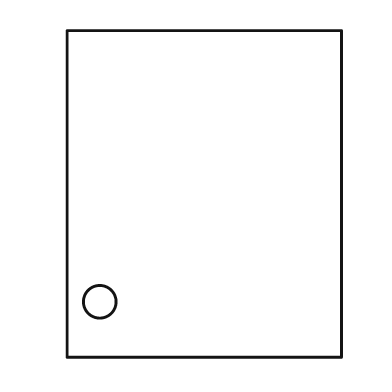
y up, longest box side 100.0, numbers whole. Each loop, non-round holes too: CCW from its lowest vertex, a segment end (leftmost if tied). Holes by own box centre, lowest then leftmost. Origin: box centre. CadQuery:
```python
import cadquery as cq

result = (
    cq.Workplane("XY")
    .moveTo(-42.0, -50.0)
    .lineTo(42.0, -50.0)
    .lineTo(42.0, 50.0)
    .lineTo(-42.0, 50.0)
    .close()
    .moveTo(-32.0, -33.0)
    .circle(5.0)
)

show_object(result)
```